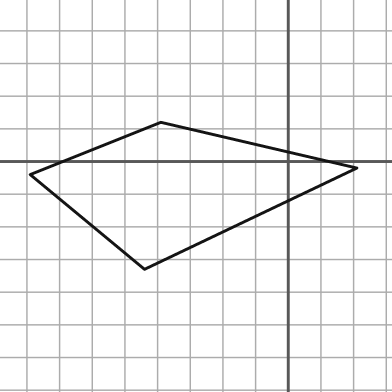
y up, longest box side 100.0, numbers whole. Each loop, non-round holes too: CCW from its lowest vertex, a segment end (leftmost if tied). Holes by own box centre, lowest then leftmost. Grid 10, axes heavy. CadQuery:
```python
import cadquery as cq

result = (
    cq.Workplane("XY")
    .moveTo(-44.0, -33.0)
    .lineTo(21.0, -2.0)
    .lineTo(-39.0, 12.0)
    .lineTo(-79.0, -4.0)
    .close()
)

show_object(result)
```